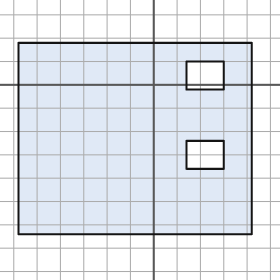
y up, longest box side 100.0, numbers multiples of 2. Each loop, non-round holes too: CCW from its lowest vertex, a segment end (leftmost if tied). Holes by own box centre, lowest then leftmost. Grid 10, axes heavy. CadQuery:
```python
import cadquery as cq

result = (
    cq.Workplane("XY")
    .moveTo(-58.0, -64.0)
    .lineTo(42.0, -64.0)
    .lineTo(42.0, 18.0)
    .lineTo(-58.0, 18.0)
    .close()
    .moveTo(14.0, -36.0)
    .lineTo(30.0, -36.0)
    .lineTo(30.0, -24.0)
    .lineTo(14.0, -24.0)
    .close()
    .moveTo(14.0, -2.0)
    .lineTo(30.0, -2.0)
    .lineTo(30.0, 10.0)
    .lineTo(14.0, 10.0)
    .close()
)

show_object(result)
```